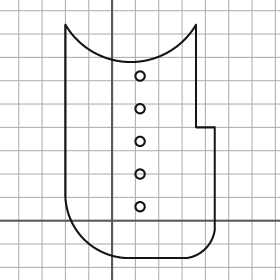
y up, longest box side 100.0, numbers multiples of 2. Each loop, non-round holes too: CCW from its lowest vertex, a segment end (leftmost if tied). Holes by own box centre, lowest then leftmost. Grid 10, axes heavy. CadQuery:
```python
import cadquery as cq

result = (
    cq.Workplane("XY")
    .moveTo(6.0, -16.0)
    .lineTo(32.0, -16.0)
    .threePointArc((40.0, -12.0), (44.0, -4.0))
    .lineTo(44.0, 40.0)
    .lineTo(36.0, 40.0)
    .lineTo(36.0, 84.0)
    .threePointArc((8.0, 68.0), (-20.0, 84.0))
    .lineTo(-20.0, 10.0)
    .threePointArc((-12.0, -8.0), (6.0, -16.0))
    .close()
    .moveTo(12.0, 6.0)
    .circle(2.0)
    .moveTo(12.0, 20.0)
    .circle(2.0)
    .moveTo(12.0, 34.0)
    .circle(2.0)
    .moveTo(12.0, 48.0)
    .circle(2.0)
    .moveTo(12.0, 62.0)
    .circle(2.0)
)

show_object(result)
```